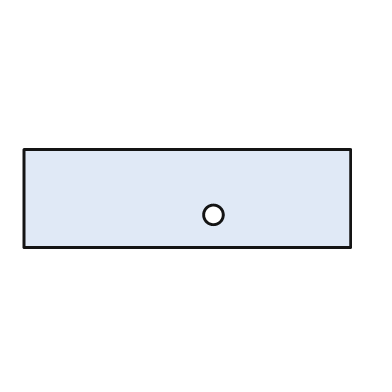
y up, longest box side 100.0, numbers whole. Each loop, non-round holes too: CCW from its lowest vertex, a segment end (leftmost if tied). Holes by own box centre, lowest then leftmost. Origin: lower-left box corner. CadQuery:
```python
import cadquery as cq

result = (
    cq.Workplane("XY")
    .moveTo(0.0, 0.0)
    .lineTo(100.0, 0.0)
    .lineTo(100.0, 30.0)
    .lineTo(0.0, 30.0)
    .close()
    .moveTo(58.0, 10.0)
    .circle(3.0)
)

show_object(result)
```